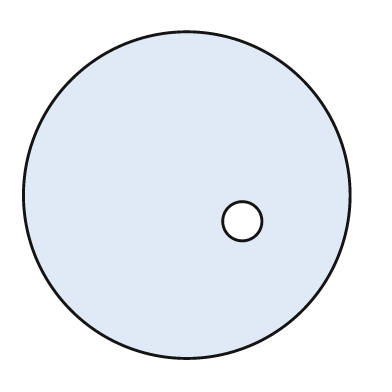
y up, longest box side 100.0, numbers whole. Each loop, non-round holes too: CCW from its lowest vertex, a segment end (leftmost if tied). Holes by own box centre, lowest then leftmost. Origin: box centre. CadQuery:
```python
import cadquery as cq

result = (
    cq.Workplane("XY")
    .moveTo(0.0, 0.0)
    .circle(50.0)
    .moveTo(17.0, -8.0)
    .circle(6.0)
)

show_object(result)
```